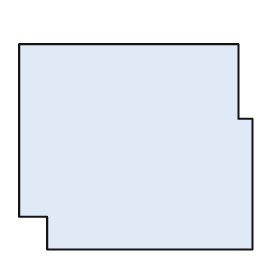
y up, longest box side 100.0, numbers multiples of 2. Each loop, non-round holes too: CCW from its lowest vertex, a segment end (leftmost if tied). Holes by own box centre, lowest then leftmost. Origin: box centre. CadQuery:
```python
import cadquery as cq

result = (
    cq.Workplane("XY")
    .moveTo(-38.0, -44.0)
    .lineTo(50.0, -44.0)
    .lineTo(50.0, 12.0)
    .lineTo(44.0, 12.0)
    .lineTo(44.0, 44.0)
    .lineTo(-50.0, 44.0)
    .lineTo(-50.0, -30.0)
    .lineTo(-38.0, -30.0)
    .close()
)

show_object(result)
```